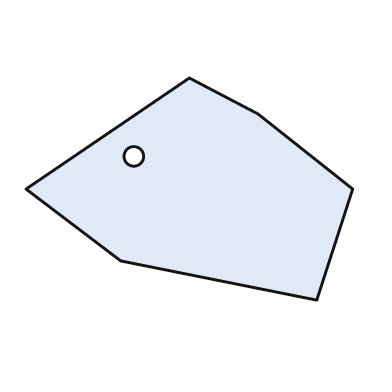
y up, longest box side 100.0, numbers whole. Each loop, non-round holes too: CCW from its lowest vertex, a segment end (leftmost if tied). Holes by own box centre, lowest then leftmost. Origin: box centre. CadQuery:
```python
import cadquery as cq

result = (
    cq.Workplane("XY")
    .moveTo(39.0, -34.0)
    .lineTo(50.0, 0.0)
    .lineTo(21.0, 23.0)
    .lineTo(0.0, 34.0)
    .lineTo(-50.0, 0.0)
    .lineTo(-21.0, -22.0)
    .close()
    .moveTo(-17.0, 10.0)
    .circle(3.0)
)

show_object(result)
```